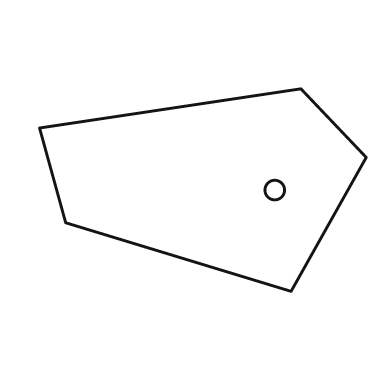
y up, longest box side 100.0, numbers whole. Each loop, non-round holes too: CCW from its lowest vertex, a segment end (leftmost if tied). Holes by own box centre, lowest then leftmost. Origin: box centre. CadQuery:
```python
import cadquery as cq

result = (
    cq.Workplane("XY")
    .moveTo(27.0, -31.0)
    .lineTo(50.0, 10.0)
    .lineTo(30.0, 31.0)
    .lineTo(-50.0, 19.0)
    .lineTo(-42.0, -10.0)
    .close()
    .moveTo(22.0, 0.0)
    .circle(3.0)
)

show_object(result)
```